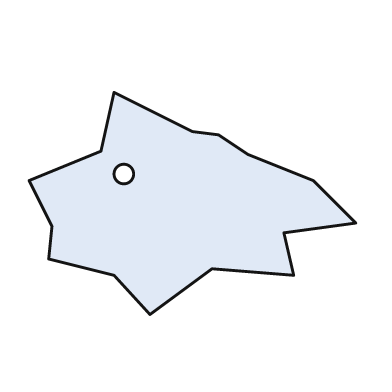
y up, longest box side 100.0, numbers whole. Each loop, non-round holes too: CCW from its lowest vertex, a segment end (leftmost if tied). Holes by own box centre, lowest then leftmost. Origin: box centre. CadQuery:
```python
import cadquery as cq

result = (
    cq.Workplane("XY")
    .moveTo(-13.0, -34.0)
    .lineTo(6.0, -20.0)
    .lineTo(31.0, -22.0)
    .lineTo(28.0, -9.0)
    .lineTo(50.0, -6.0)
    .lineTo(37.0, 7.0)
    .lineTo(17.0, 15.0)
    .lineTo(8.0, 21.0)
    .lineTo(0.0, 22.0)
    .lineTo(-24.0, 34.0)
    .lineTo(-28.0, 16.0)
    .lineTo(-50.0, 7.0)
    .lineTo(-43.0, -7.0)
    .lineTo(-44.0, -17.0)
    .lineTo(-24.0, -22.0)
    .close()
    .moveTo(-21.0, 9.0)
    .circle(3.0)
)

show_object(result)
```